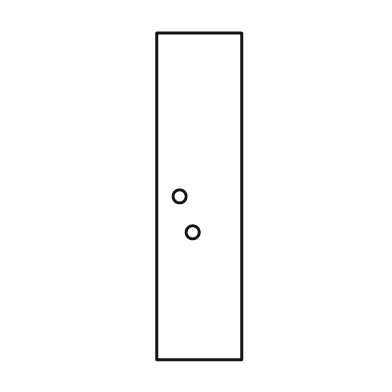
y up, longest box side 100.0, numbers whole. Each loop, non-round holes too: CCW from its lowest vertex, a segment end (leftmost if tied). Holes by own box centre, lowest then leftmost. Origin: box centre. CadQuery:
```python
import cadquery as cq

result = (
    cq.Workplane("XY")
    .moveTo(-13.0, -50.0)
    .lineTo(13.0, -50.0)
    .lineTo(13.0, 50.0)
    .lineTo(-13.0, 50.0)
    .close()
    .moveTo(-2.0, -11.0)
    .circle(2.0)
    .moveTo(-6.0, 0.0)
    .circle(2.0)
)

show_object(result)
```